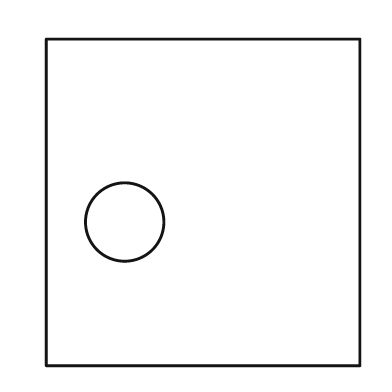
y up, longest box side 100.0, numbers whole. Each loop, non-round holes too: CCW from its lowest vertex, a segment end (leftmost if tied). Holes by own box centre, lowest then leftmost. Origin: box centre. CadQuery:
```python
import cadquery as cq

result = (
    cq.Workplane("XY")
    .moveTo(-48.0, -50.0)
    .lineTo(48.0, -50.0)
    .lineTo(48.0, 50.0)
    .lineTo(-48.0, 50.0)
    .close()
    .moveTo(-24.0, -6.0)
    .circle(12.0)
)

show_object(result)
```